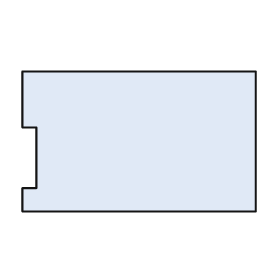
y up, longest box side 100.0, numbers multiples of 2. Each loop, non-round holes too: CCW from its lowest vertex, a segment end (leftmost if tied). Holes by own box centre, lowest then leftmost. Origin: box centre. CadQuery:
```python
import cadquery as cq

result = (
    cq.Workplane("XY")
    .moveTo(-50.0, -30.0)
    .lineTo(50.0, -30.0)
    .lineTo(50.0, 30.0)
    .lineTo(-50.0, 30.0)
    .lineTo(-50.0, 6.0)
    .lineTo(-44.0, 6.0)
    .lineTo(-44.0, -20.0)
    .lineTo(-50.0, -20.0)
    .close()
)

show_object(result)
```